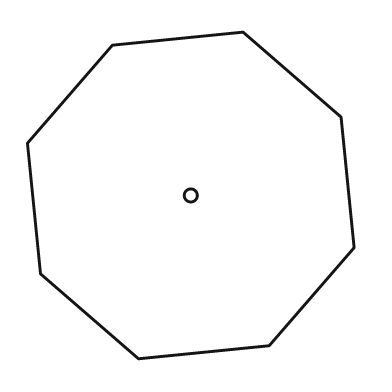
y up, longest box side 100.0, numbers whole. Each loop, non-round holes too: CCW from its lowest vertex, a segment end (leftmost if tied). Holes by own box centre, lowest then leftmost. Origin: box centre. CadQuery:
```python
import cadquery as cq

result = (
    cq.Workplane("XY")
    .moveTo(-16.0, -50.0)
    .lineTo(24.0, -46.0)
    .lineTo(50.0, -16.0)
    .lineTo(46.0, 24.0)
    .lineTo(16.0, 50.0)
    .lineTo(-24.0, 46.0)
    .lineTo(-50.0, 16.0)
    .lineTo(-46.0, -24.0)
    .close()
    .moveTo(0.0, 0.0)
    .circle(2.0)
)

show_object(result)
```